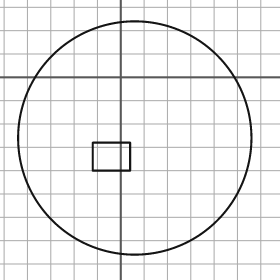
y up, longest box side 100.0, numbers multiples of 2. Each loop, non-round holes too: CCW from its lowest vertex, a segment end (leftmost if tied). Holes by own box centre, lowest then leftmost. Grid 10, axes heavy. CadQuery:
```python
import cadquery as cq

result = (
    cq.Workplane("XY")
    .moveTo(6.0, -26.0)
    .circle(50.0)
    .moveTo(-12.0, -40.0)
    .lineTo(4.0, -40.0)
    .lineTo(4.0, -28.0)
    .lineTo(-12.0, -28.0)
    .close()
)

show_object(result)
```